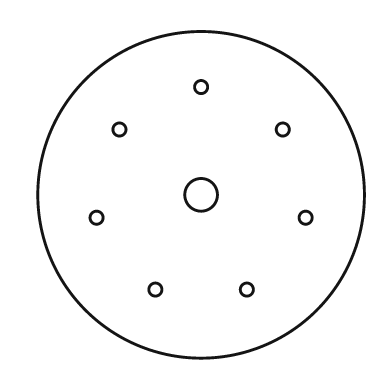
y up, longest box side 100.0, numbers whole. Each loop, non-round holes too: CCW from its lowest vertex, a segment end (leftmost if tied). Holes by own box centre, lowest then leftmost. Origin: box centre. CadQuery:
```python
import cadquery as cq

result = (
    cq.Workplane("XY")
    .moveTo(0.0, 0.0)
    .circle(50.0)
    .moveTo(-14.0, -29.0)
    .circle(2.0)
    .moveTo(14.0, -29.0)
    .circle(2.0)
    .moveTo(-32.0, -7.0)
    .circle(2.0)
    .moveTo(32.0, -7.0)
    .circle(2.0)
    .moveTo(0.0, 0.0)
    .circle(5.0)
    .moveTo(-25.0, 20.0)
    .circle(2.0)
    .moveTo(25.0, 20.0)
    .circle(2.0)
    .moveTo(0.0, 33.0)
    .circle(2.0)
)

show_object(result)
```